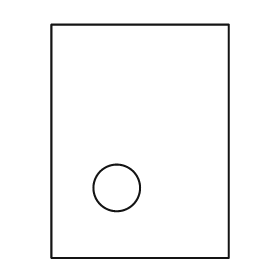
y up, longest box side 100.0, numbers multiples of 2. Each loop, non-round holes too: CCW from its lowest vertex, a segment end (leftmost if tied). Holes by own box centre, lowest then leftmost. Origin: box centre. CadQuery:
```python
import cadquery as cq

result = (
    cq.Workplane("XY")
    .moveTo(-38.0, -50.0)
    .lineTo(38.0, -50.0)
    .lineTo(38.0, 50.0)
    .lineTo(-38.0, 50.0)
    .close()
    .moveTo(-10.0, -20.0)
    .circle(10.0)
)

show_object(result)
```